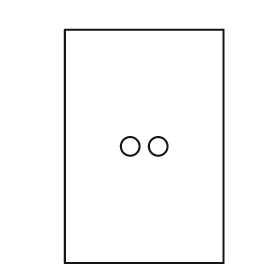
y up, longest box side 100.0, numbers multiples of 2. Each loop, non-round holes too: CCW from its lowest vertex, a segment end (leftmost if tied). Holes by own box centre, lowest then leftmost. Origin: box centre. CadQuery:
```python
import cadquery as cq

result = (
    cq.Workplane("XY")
    .moveTo(-34.0, -50.0)
    .lineTo(34.0, -50.0)
    .lineTo(34.0, 50.0)
    .lineTo(-34.0, 50.0)
    .close()
    .moveTo(-6.0, 0.0)
    .circle(4.0)
    .moveTo(6.0, 0.0)
    .circle(4.0)
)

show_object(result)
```